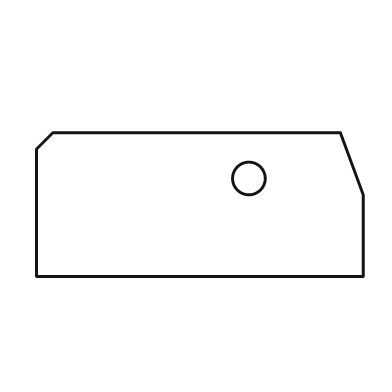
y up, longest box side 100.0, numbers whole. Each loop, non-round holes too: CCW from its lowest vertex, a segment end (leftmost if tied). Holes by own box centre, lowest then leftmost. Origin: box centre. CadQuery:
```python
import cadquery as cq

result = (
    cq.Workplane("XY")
    .moveTo(-50.0, -22.0)
    .lineTo(50.0, -22.0)
    .lineTo(50.0, 3.0)
    .lineTo(43.0, 22.0)
    .lineTo(-45.0, 22.0)
    .lineTo(-50.0, 17.0)
    .close()
    .moveTo(15.0, 8.0)
    .circle(5.0)
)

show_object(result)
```